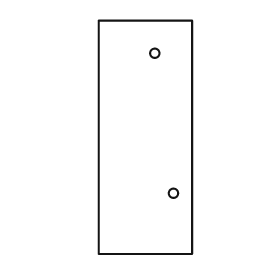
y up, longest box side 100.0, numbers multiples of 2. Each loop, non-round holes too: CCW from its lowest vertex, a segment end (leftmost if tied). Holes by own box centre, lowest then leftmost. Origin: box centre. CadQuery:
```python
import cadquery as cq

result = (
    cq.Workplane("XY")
    .moveTo(-20.0, -50.0)
    .lineTo(20.0, -50.0)
    .lineTo(20.0, 50.0)
    .lineTo(-20.0, 50.0)
    .close()
    .moveTo(12.0, -24.0)
    .circle(2.0)
    .moveTo(4.0, 36.0)
    .circle(2.0)
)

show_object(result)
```